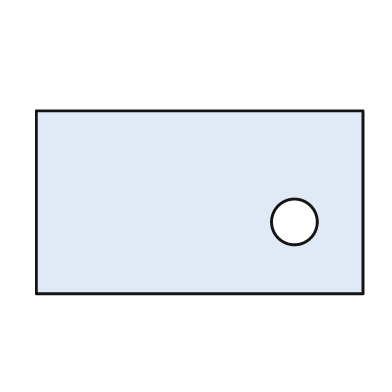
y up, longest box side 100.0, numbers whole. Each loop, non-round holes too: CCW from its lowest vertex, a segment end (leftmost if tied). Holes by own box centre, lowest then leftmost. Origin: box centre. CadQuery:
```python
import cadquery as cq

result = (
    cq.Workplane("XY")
    .moveTo(-50.0, -28.0)
    .lineTo(50.0, -28.0)
    .lineTo(50.0, 28.0)
    .lineTo(-50.0, 28.0)
    .close()
    .moveTo(29.0, -6.0)
    .circle(7.0)
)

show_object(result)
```